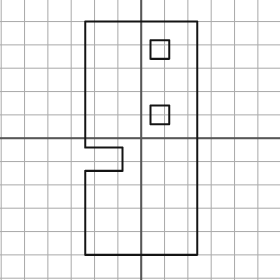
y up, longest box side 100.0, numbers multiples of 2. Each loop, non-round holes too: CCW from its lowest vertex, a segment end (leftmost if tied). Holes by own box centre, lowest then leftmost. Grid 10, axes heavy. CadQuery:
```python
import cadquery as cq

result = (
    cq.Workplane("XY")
    .moveTo(-24.0, -50.0)
    .lineTo(24.0, -50.0)
    .lineTo(24.0, 50.0)
    .lineTo(-24.0, 50.0)
    .lineTo(-24.0, -4.0)
    .lineTo(-8.0, -4.0)
    .lineTo(-8.0, -14.0)
    .lineTo(-24.0, -14.0)
    .close()
    .moveTo(4.0, 6.0)
    .lineTo(12.0, 6.0)
    .lineTo(12.0, 14.0)
    .lineTo(4.0, 14.0)
    .close()
    .moveTo(4.0, 34.0)
    .lineTo(12.0, 34.0)
    .lineTo(12.0, 42.0)
    .lineTo(4.0, 42.0)
    .close()
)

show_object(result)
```